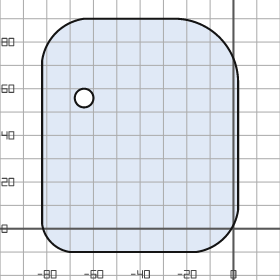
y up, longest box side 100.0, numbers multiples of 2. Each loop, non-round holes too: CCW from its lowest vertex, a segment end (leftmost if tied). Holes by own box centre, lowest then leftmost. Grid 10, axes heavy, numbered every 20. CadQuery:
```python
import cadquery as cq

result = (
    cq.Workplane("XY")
    .moveTo(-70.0, -10.0)
    .lineTo(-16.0, -10.0)
    .threePointArc((-4.0, -4.0), (2.0, 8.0))
    .lineTo(2.0, 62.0)
    .threePointArc((-6.0, 82.0), (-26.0, 90.0))
    .lineTo(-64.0, 90.0)
    .threePointArc((-76.0, 84.0), (-82.0, 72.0))
    .lineTo(-82.0, 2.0)
    .threePointArc((-78.0, -6.0), (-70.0, -10.0))
    .close()
    .moveTo(-64.0, 56.0)
    .circle(4.0)
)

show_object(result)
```